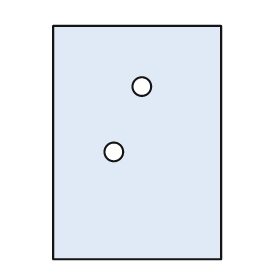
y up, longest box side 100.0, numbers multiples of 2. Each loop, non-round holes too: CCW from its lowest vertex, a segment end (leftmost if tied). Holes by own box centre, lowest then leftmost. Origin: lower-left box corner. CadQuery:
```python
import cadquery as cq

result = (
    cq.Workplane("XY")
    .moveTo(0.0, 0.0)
    .lineTo(72.0, 0.0)
    .lineTo(72.0, 100.0)
    .lineTo(0.0, 100.0)
    .close()
    .moveTo(26.0, 46.0)
    .circle(4.0)
    .moveTo(38.0, 74.0)
    .circle(4.0)
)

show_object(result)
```